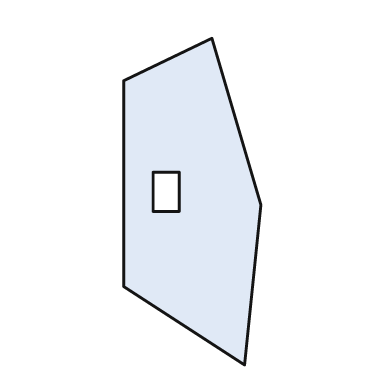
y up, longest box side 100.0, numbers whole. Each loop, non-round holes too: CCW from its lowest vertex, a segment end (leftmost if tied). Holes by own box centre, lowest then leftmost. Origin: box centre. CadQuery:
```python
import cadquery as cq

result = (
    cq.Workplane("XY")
    .moveTo(16.0, -50.0)
    .lineTo(21.0, -1.0)
    .lineTo(6.0, 50.0)
    .lineTo(-21.0, 37.0)
    .lineTo(-21.0, -26.0)
    .close()
    .moveTo(-12.0, -3.0)
    .lineTo(-4.0, -3.0)
    .lineTo(-4.0, 9.0)
    .lineTo(-12.0, 9.0)
    .close()
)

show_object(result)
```